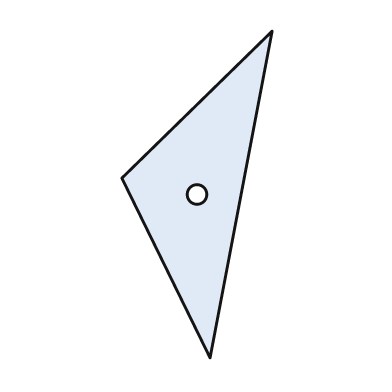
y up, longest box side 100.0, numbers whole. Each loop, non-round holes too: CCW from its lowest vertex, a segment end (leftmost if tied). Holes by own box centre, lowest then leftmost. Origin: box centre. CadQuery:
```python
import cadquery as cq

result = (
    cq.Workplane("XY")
    .moveTo(4.0, -50.0)
    .lineTo(23.0, 50.0)
    .lineTo(-23.0, 5.0)
    .close()
    .moveTo(0.0, 0.0)
    .circle(3.0)
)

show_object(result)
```